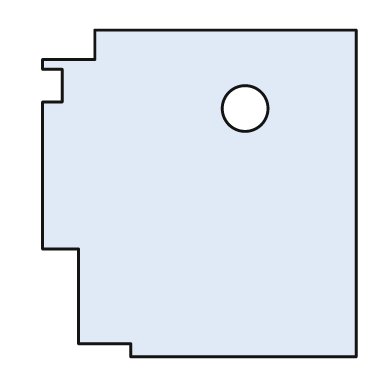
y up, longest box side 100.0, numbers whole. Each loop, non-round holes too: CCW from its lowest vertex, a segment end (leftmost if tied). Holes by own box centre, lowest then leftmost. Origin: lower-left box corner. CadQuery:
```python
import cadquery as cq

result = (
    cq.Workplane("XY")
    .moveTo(27.0, 0.0)
    .lineTo(96.0, 0.0)
    .lineTo(96.0, 100.0)
    .lineTo(16.0, 100.0)
    .lineTo(16.0, 91.0)
    .lineTo(0.0, 91.0)
    .lineTo(0.0, 88.0)
    .lineTo(6.0, 88.0)
    .lineTo(6.0, 78.0)
    .lineTo(0.0, 78.0)
    .lineTo(0.0, 33.0)
    .lineTo(11.0, 33.0)
    .lineTo(11.0, 4.0)
    .lineTo(27.0, 4.0)
    .close()
    .moveTo(62.0, 76.0)
    .circle(7.0)
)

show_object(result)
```